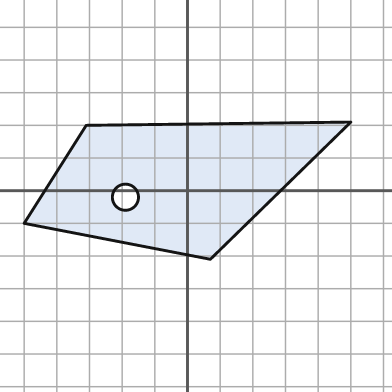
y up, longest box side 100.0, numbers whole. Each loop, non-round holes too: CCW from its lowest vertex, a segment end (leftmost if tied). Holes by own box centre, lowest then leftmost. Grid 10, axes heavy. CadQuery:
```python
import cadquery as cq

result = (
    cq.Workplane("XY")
    .moveTo(7.0, -21.0)
    .lineTo(50.0, 21.0)
    .lineTo(-31.0, 20.0)
    .lineTo(-50.0, -10.0)
    .close()
    .moveTo(-19.0, -2.0)
    .circle(4.0)
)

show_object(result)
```